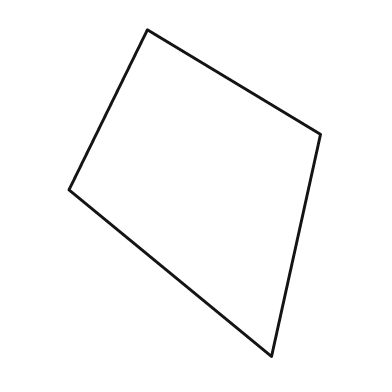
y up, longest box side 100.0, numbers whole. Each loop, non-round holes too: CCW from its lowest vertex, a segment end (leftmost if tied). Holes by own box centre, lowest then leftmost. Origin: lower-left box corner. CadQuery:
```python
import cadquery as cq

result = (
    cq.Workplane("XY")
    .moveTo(62.0, 0.0)
    .lineTo(77.0, 68.0)
    .lineTo(24.0, 100.0)
    .lineTo(0.0, 51.0)
    .close()
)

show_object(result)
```